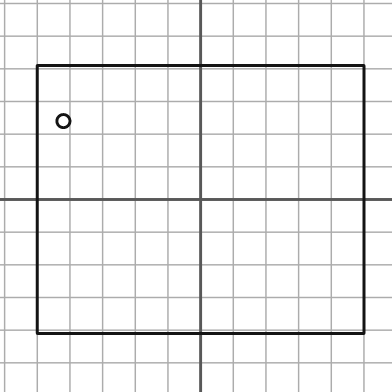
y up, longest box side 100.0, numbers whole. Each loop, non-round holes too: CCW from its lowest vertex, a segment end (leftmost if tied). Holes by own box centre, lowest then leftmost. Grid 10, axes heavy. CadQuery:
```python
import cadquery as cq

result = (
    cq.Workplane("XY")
    .moveTo(-50.0, -41.0)
    .lineTo(50.0, -41.0)
    .lineTo(50.0, 41.0)
    .lineTo(-50.0, 41.0)
    .close()
    .moveTo(-42.0, 24.0)
    .circle(2.0)
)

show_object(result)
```